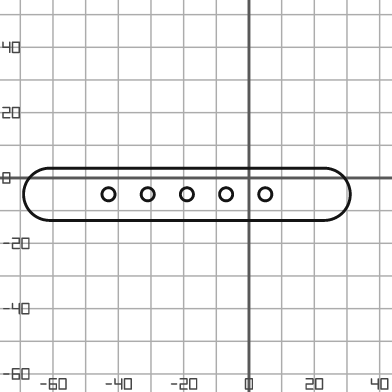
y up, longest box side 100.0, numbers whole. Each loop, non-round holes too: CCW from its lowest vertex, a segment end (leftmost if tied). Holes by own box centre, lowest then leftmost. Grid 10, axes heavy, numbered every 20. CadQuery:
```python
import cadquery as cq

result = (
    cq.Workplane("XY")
    .moveTo(-61.0, -13.0)
    .lineTo(23.0, -13.0)
    .threePointArc((31.0, -5.0), (23.0, 3.0))
    .lineTo(-61.0, 3.0)
    .threePointArc((-69.0, -5.0), (-61.0, -13.0))
    .close()
    .moveTo(-43.0, -5.0)
    .circle(2.0)
    .moveTo(-31.0, -5.0)
    .circle(2.0)
    .moveTo(-19.0, -5.0)
    .circle(2.0)
    .moveTo(-7.0, -5.0)
    .circle(2.0)
    .moveTo(5.0, -5.0)
    .circle(2.0)
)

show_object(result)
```